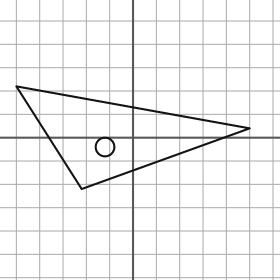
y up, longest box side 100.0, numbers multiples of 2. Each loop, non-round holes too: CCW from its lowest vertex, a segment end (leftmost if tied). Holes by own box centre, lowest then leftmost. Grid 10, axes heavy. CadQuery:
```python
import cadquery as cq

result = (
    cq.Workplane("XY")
    .moveTo(-22.0, -22.0)
    .lineTo(50.0, 4.0)
    .lineTo(-50.0, 22.0)
    .close()
    .moveTo(-12.0, -4.0)
    .circle(4.0)
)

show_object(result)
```